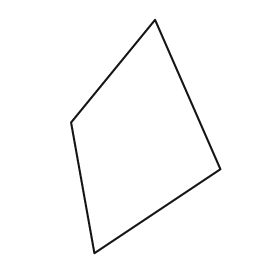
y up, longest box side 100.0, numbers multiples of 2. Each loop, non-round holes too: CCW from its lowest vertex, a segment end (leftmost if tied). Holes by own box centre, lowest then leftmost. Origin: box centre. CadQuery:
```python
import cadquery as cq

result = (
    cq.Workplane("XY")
    .moveTo(-22.0, -50.0)
    .lineTo(32.0, -14.0)
    .lineTo(4.0, 50.0)
    .lineTo(-32.0, 6.0)
    .close()
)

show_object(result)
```